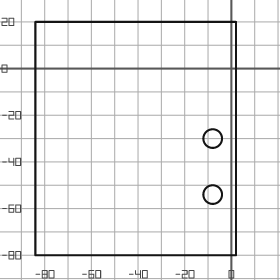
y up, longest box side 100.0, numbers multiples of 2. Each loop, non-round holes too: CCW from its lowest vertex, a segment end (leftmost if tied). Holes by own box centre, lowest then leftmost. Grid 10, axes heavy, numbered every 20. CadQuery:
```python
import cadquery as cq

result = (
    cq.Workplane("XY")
    .moveTo(-84.0, -80.0)
    .lineTo(2.0, -80.0)
    .lineTo(2.0, 20.0)
    .lineTo(-84.0, 20.0)
    .close()
    .moveTo(-8.0, -54.0)
    .circle(4.0)
    .moveTo(-8.0, -30.0)
    .circle(4.0)
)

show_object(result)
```